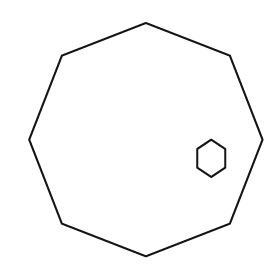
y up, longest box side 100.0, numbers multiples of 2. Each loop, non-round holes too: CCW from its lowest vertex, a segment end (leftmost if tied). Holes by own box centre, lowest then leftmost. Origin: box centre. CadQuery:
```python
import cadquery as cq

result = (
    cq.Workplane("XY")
    .moveTo(0.0, -50.0)
    .lineTo(36.0, -36.0)
    .lineTo(50.0, 0.0)
    .lineTo(36.0, 36.0)
    .lineTo(0.0, 50.0)
    .lineTo(-36.0, 36.0)
    .lineTo(-50.0, 0.0)
    .lineTo(-36.0, -36.0)
    .close()
    .moveTo(28.0, -16.0)
    .lineTo(34.0, -12.0)
    .lineTo(34.0, -4.0)
    .lineTo(28.0, 0.0)
    .lineTo(22.0, -4.0)
    .lineTo(22.0, -12.0)
    .close()
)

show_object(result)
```